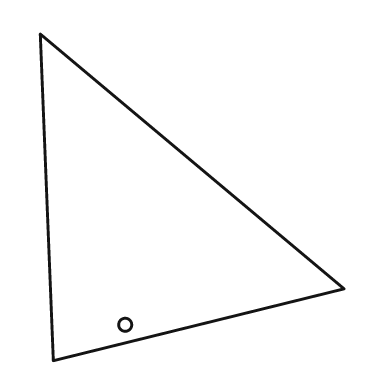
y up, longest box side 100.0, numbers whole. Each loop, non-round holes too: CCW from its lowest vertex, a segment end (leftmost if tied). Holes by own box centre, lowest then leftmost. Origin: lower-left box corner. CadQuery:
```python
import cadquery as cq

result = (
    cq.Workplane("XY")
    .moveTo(4.0, 0.0)
    .lineTo(93.0, 22.0)
    .lineTo(0.0, 100.0)
    .close()
    .moveTo(26.0, 11.0)
    .circle(2.0)
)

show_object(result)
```